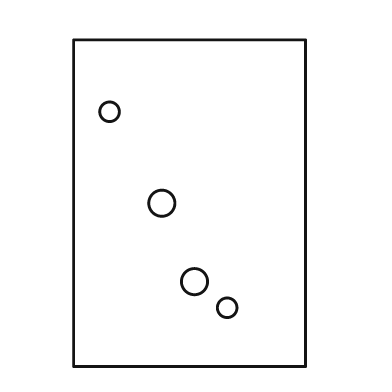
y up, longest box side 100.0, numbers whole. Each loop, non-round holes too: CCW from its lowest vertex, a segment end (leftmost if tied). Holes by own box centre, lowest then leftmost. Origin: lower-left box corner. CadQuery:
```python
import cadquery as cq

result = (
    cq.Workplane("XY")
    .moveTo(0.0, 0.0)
    .lineTo(71.0, 0.0)
    .lineTo(71.0, 100.0)
    .lineTo(0.0, 100.0)
    .close()
    .moveTo(47.0, 18.0)
    .circle(3.0)
    .moveTo(37.0, 26.0)
    .circle(4.0)
    .moveTo(27.0, 50.0)
    .circle(4.0)
    .moveTo(11.0, 78.0)
    .circle(3.0)
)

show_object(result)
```